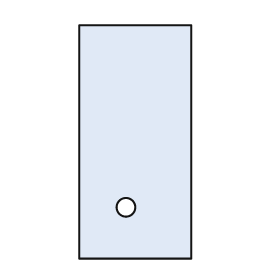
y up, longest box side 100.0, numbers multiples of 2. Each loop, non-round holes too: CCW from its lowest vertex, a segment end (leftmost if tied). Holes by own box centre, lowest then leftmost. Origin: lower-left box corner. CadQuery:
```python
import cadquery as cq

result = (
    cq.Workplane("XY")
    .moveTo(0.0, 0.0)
    .lineTo(48.0, 0.0)
    .lineTo(48.0, 100.0)
    .lineTo(0.0, 100.0)
    .close()
    .moveTo(20.0, 22.0)
    .circle(4.0)
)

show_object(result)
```